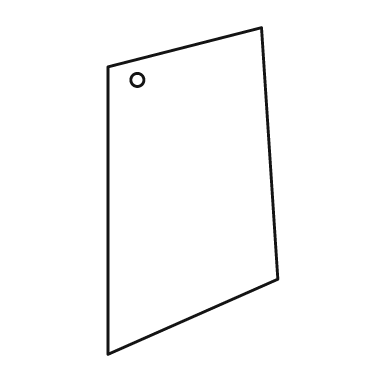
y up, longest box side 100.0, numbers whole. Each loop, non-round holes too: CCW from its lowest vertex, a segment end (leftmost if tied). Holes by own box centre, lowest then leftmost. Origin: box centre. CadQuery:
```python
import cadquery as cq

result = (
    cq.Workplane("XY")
    .moveTo(-26.0, -50.0)
    .lineTo(26.0, -27.0)
    .lineTo(21.0, 50.0)
    .lineTo(-26.0, 38.0)
    .close()
    .moveTo(-17.0, 34.0)
    .circle(2.0)
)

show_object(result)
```